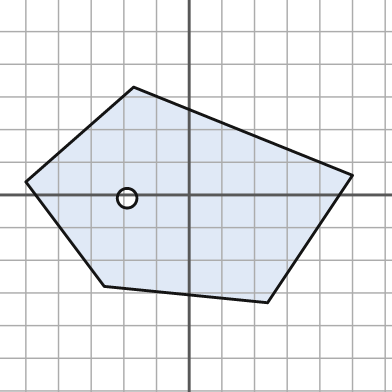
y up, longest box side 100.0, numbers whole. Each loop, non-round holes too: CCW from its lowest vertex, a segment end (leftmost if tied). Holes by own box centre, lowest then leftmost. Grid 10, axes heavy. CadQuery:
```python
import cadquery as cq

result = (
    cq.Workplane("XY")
    .moveTo(24.0, -33.0)
    .lineTo(50.0, 6.0)
    .lineTo(-17.0, 33.0)
    .lineTo(-50.0, 4.0)
    .lineTo(-26.0, -28.0)
    .close()
    .moveTo(-19.0, -1.0)
    .circle(3.0)
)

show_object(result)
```